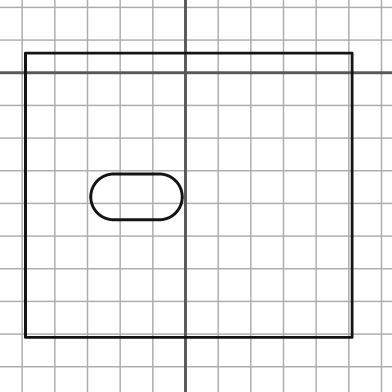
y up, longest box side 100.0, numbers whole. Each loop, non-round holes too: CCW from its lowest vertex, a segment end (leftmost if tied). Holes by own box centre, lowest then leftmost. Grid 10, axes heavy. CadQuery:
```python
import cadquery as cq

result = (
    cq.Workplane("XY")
    .moveTo(-49.0, -81.0)
    .lineTo(51.0, -81.0)
    .lineTo(51.0, 6.0)
    .lineTo(-49.0, 6.0)
    .close()
    .moveTo(-22.0, -45.0)
    .lineTo(-8.0, -45.0)
    .threePointArc((-1.0, -38.0), (-8.0, -31.0))
    .lineTo(-22.0, -31.0)
    .threePointArc((-29.0, -38.0), (-22.0, -45.0))
    .close()
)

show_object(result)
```